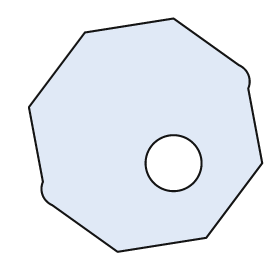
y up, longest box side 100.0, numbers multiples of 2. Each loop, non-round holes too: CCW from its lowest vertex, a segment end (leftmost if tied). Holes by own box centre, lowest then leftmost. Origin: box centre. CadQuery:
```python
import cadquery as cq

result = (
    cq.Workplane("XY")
    .moveTo(-12.0, -50.0)
    .lineTo(26.0, -44.0)
    .lineTo(50.0, -12.0)
    .lineTo(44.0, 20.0)
    .threePointArc((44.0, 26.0), (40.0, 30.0))
    .lineTo(12.0, 50.0)
    .lineTo(-26.0, 44.0)
    .lineTo(-50.0, 12.0)
    .lineTo(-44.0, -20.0)
    .threePointArc((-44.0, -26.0), (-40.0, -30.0))
    .close()
    .moveTo(12.0, -12.0)
    .circle(12.0)
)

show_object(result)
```